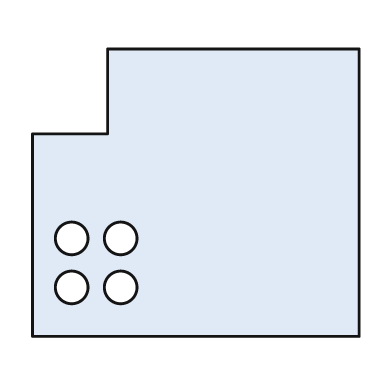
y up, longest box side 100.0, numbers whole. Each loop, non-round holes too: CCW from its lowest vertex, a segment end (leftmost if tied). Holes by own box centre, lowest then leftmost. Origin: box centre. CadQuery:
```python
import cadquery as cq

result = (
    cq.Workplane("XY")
    .moveTo(-50.0, -44.0)
    .lineTo(50.0, -44.0)
    .lineTo(50.0, 44.0)
    .lineTo(-27.0, 44.0)
    .lineTo(-27.0, 18.0)
    .lineTo(-50.0, 18.0)
    .close()
    .moveTo(-38.0, -29.0)
    .circle(5.0)
    .moveTo(-23.0, -29.0)
    .circle(5.0)
    .moveTo(-38.0, -14.0)
    .circle(5.0)
    .moveTo(-23.0, -14.0)
    .circle(5.0)
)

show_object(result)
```